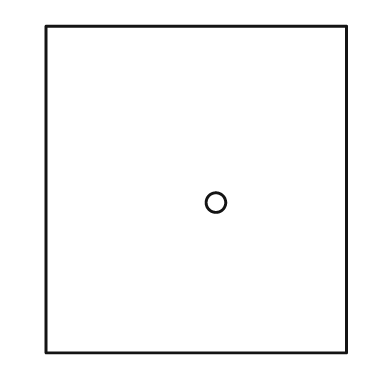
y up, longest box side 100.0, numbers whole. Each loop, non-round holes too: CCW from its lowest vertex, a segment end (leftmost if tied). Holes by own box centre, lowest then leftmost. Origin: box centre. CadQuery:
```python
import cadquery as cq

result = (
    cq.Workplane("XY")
    .moveTo(-46.0, -50.0)
    .lineTo(46.0, -50.0)
    .lineTo(46.0, 50.0)
    .lineTo(-46.0, 50.0)
    .close()
    .moveTo(6.0, -4.0)
    .circle(3.0)
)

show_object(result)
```